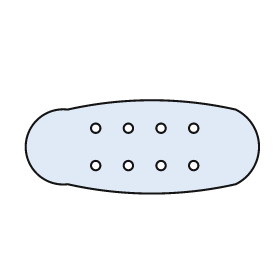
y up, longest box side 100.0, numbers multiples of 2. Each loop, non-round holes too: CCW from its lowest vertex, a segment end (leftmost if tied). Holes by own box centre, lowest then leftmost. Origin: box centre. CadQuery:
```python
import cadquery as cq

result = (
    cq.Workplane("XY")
    .moveTo(-32.0, -16.0)
    .threePointArc((4.0, -20.0), (40.0, -16.0))
    .threePointArc((50.0, 0.0), (40.0, 16.0))
    .threePointArc((4.0, 20.0), (-32.0, 16.0))
    .threePointArc((-50.0, 0.0), (-32.0, -16.0))
    .close()
    .moveTo(-20.0, -8.0)
    .circle(2.0)
    .moveTo(-6.0, -8.0)
    .circle(2.0)
    .moveTo(8.0, -8.0)
    .circle(2.0)
    .moveTo(22.0, -8.0)
    .circle(2.0)
    .moveTo(-20.0, 8.0)
    .circle(2.0)
    .moveTo(-6.0, 8.0)
    .circle(2.0)
    .moveTo(8.0, 8.0)
    .circle(2.0)
    .moveTo(22.0, 8.0)
    .circle(2.0)
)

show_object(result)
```